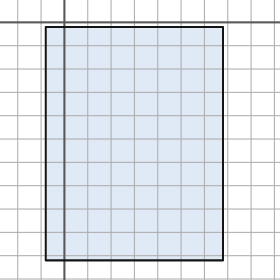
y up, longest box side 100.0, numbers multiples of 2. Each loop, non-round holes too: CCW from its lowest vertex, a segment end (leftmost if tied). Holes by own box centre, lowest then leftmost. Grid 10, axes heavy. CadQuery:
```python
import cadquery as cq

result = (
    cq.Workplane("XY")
    .moveTo(-8.0, -102.0)
    .lineTo(68.0, -102.0)
    .lineTo(68.0, -2.0)
    .lineTo(-8.0, -2.0)
    .close()
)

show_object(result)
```